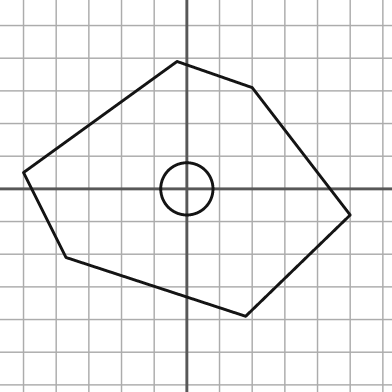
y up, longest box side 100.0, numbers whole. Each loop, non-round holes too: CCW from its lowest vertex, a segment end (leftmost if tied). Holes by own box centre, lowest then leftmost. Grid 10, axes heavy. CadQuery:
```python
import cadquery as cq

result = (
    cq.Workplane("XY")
    .moveTo(18.0, -39.0)
    .lineTo(50.0, -8.0)
    .lineTo(20.0, 31.0)
    .lineTo(-3.0, 39.0)
    .lineTo(-50.0, 5.0)
    .lineTo(-37.0, -21.0)
    .close()
    .moveTo(0.0, 0.0)
    .circle(8.0)
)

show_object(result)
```